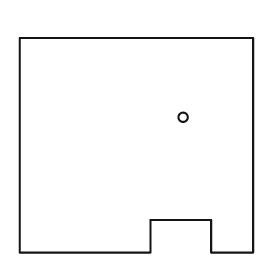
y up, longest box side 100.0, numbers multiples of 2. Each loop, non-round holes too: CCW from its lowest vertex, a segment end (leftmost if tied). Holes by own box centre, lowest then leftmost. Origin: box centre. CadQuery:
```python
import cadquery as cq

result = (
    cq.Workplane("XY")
    .moveTo(-50.0, -46.0)
    .lineTo(6.0, -46.0)
    .lineTo(6.0, -32.0)
    .lineTo(32.0, -32.0)
    .lineTo(32.0, -46.0)
    .lineTo(50.0, -46.0)
    .lineTo(50.0, 46.0)
    .lineTo(-50.0, 46.0)
    .close()
    .moveTo(20.0, 12.0)
    .circle(2.0)
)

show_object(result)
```